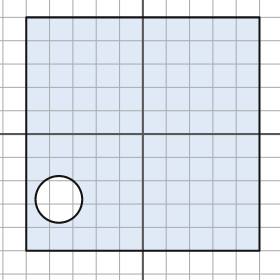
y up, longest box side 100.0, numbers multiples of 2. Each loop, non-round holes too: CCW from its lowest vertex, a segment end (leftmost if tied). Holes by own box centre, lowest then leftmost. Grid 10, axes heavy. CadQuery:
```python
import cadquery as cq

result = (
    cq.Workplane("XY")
    .moveTo(-50.0, -50.0)
    .lineTo(50.0, -50.0)
    .lineTo(50.0, 50.0)
    .lineTo(-50.0, 50.0)
    .close()
    .moveTo(-36.0, -28.0)
    .circle(10.0)
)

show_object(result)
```